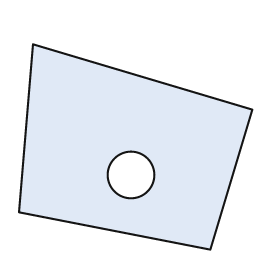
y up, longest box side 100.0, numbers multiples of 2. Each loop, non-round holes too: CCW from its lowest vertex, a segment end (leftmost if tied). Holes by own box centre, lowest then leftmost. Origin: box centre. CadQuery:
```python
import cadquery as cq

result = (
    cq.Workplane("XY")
    .moveTo(32.0, -44.0)
    .lineTo(50.0, 16.0)
    .lineTo(-44.0, 44.0)
    .lineTo(-50.0, -28.0)
    .close()
    .moveTo(-2.0, -12.0)
    .circle(10.0)
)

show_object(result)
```